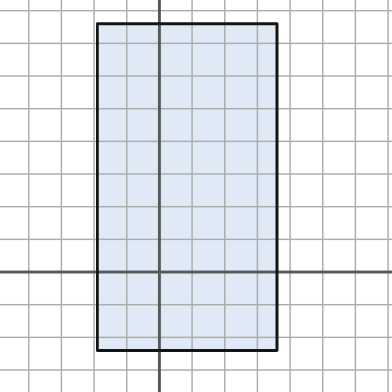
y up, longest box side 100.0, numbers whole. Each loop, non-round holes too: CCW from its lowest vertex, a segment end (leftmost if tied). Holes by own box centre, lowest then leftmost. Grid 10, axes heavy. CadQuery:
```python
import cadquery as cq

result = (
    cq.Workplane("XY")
    .moveTo(-19.0, -24.0)
    .lineTo(36.0, -24.0)
    .lineTo(36.0, 76.0)
    .lineTo(-19.0, 76.0)
    .close()
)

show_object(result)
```